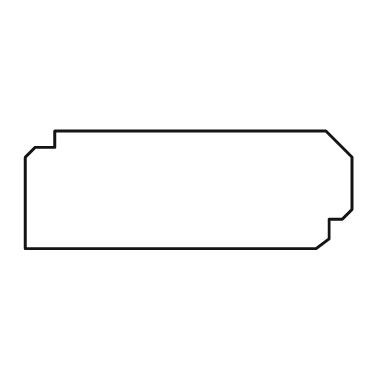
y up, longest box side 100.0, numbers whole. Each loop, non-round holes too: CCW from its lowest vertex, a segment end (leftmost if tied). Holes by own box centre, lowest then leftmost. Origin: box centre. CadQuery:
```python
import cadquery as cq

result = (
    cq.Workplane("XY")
    .moveTo(-50.0, -18.0)
    .lineTo(39.0, -18.0)
    .lineTo(43.0, -15.0)
    .lineTo(43.0, -9.0)
    .lineTo(47.0, -9.0)
    .lineTo(50.0, -6.0)
    .lineTo(50.0, 10.0)
    .lineTo(42.0, 18.0)
    .lineTo(-41.0, 18.0)
    .lineTo(-41.0, 13.0)
    .lineTo(-47.0, 13.0)
    .lineTo(-50.0, 10.0)
    .close()
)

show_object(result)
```